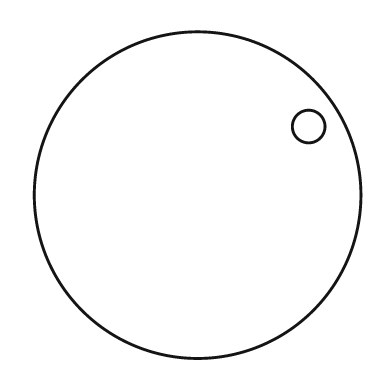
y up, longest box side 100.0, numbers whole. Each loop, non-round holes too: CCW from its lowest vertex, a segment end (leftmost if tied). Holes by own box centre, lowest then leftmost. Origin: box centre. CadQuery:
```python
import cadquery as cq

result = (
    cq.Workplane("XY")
    .moveTo(0.0, 0.0)
    .circle(50.0)
    .moveTo(34.0, 21.0)
    .circle(5.0)
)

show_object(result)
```